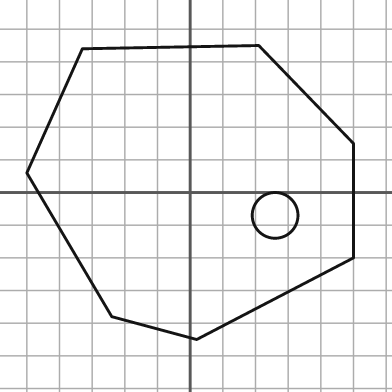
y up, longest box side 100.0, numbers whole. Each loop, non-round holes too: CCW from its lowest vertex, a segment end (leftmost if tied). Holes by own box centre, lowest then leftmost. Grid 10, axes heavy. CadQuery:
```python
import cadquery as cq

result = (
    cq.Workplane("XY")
    .moveTo(2.0, -45.0)
    .lineTo(50.0, -20.0)
    .lineTo(50.0, 15.0)
    .lineTo(21.0, 45.0)
    .lineTo(-33.0, 44.0)
    .lineTo(-50.0, 6.0)
    .lineTo(-24.0, -38.0)
    .close()
    .moveTo(26.0, -7.0)
    .circle(7.0)
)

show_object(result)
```